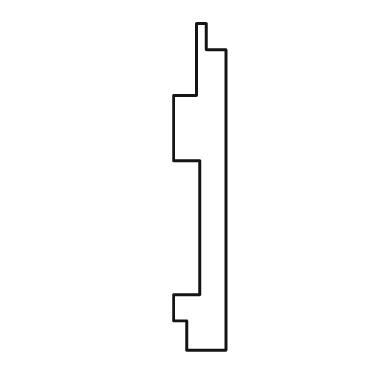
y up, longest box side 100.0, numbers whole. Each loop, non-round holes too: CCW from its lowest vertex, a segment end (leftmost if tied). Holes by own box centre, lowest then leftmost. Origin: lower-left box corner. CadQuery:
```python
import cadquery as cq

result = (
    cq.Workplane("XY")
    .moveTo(4.0, 0.0)
    .lineTo(16.0, 0.0)
    .lineTo(16.0, 92.0)
    .lineTo(10.0, 92.0)
    .lineTo(10.0, 100.0)
    .lineTo(7.0, 100.0)
    .lineTo(7.0, 78.0)
    .lineTo(0.0, 78.0)
    .lineTo(0.0, 58.0)
    .lineTo(8.0, 58.0)
    .lineTo(8.0, 17.0)
    .lineTo(0.0, 17.0)
    .lineTo(0.0, 9.0)
    .lineTo(4.0, 9.0)
    .close()
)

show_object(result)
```